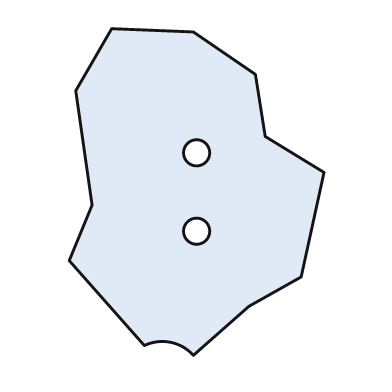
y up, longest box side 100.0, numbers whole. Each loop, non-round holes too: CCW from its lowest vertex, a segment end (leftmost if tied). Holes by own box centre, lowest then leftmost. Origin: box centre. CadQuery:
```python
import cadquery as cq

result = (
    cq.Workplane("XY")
    .moveTo(-1.0, -50.0)
    .lineTo(16.0, -35.0)
    .lineTo(32.0, -26.0)
    .lineTo(39.0, 6.0)
    .lineTo(21.0, 17.0)
    .lineTo(18.0, 36.0)
    .lineTo(-1.0, 49.0)
    .lineTo(-26.0, 50.0)
    .lineTo(-37.0, 31.0)
    .lineTo(-32.0, -4.0)
    .lineTo(-39.0, -21.0)
    .lineTo(-16.0, -47.0)
    .threePointArc((-8.0, -46.0), (-1.0, -50.0))
    .close()
    .moveTo(0.0, -12.0)
    .circle(4.0)
    .moveTo(0.0, 12.0)
    .circle(4.0)
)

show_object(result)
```